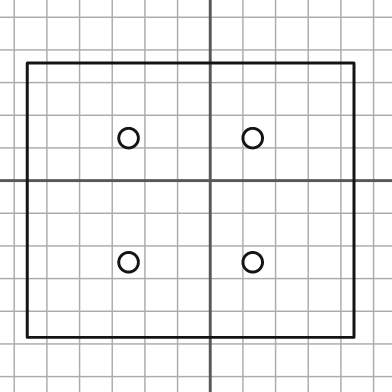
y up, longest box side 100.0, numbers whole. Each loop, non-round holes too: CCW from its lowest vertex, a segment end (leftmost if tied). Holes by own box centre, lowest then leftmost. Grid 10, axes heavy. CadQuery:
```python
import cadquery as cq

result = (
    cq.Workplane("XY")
    .moveTo(-56.0, -48.0)
    .lineTo(44.0, -48.0)
    .lineTo(44.0, 36.0)
    .lineTo(-56.0, 36.0)
    .close()
    .moveTo(-25.0, -25.0)
    .circle(3.0)
    .moveTo(13.0, -25.0)
    .circle(3.0)
    .moveTo(-25.0, 13.0)
    .circle(3.0)
    .moveTo(13.0, 13.0)
    .circle(3.0)
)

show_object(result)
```